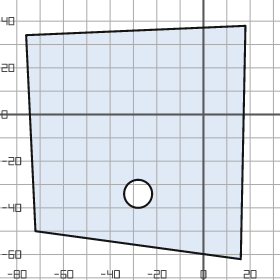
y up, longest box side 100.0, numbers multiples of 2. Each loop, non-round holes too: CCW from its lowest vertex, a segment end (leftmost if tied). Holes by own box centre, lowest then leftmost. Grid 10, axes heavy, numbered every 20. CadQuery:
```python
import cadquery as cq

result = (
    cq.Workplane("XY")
    .moveTo(16.0, -62.0)
    .lineTo(18.0, 38.0)
    .lineTo(-76.0, 34.0)
    .lineTo(-72.0, -50.0)
    .close()
    .moveTo(-28.0, -34.0)
    .circle(6.0)
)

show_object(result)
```